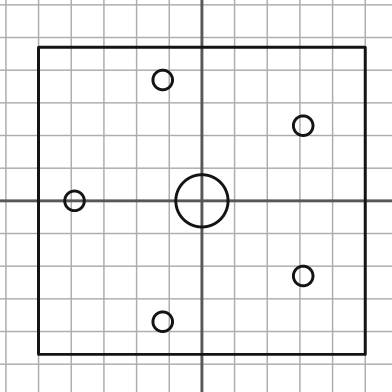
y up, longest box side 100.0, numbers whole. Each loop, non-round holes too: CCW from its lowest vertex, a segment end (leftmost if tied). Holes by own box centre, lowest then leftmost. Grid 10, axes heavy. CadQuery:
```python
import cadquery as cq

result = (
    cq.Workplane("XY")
    .moveTo(-50.0, -47.0)
    .lineTo(50.0, -47.0)
    .lineTo(50.0, 47.0)
    .lineTo(-50.0, 47.0)
    .close()
    .moveTo(-12.0, -37.0)
    .circle(3.0)
    .moveTo(31.0, -23.0)
    .circle(3.0)
    .moveTo(-39.0, 0.0)
    .circle(3.0)
    .moveTo(0.0, 0.0)
    .circle(8.0)
    .moveTo(31.0, 23.0)
    .circle(3.0)
    .moveTo(-12.0, 37.0)
    .circle(3.0)
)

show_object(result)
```